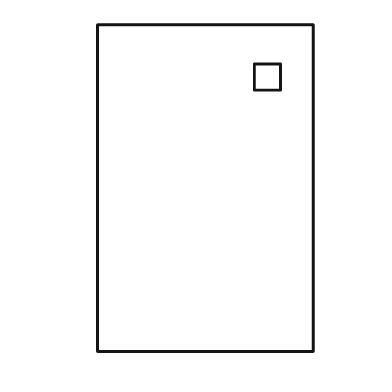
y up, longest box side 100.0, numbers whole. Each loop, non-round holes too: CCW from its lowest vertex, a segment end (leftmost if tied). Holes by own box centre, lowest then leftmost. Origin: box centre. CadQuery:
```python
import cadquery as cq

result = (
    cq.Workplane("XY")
    .moveTo(-33.0, -50.0)
    .lineTo(33.0, -50.0)
    .lineTo(33.0, 50.0)
    .lineTo(-33.0, 50.0)
    .close()
    .moveTo(15.0, 30.0)
    .lineTo(23.0, 30.0)
    .lineTo(23.0, 38.0)
    .lineTo(15.0, 38.0)
    .close()
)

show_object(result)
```